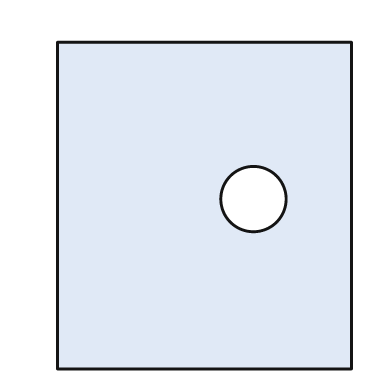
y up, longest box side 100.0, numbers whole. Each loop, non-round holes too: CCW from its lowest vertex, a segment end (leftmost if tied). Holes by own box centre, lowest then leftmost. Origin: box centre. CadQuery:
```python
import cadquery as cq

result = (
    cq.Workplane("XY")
    .moveTo(-45.0, -50.0)
    .lineTo(45.0, -50.0)
    .lineTo(45.0, 50.0)
    .lineTo(-45.0, 50.0)
    .close()
    .moveTo(15.0, 2.0)
    .circle(10.0)
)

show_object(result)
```